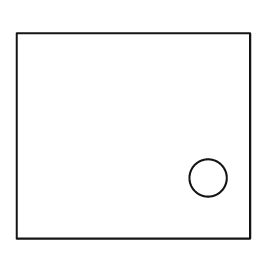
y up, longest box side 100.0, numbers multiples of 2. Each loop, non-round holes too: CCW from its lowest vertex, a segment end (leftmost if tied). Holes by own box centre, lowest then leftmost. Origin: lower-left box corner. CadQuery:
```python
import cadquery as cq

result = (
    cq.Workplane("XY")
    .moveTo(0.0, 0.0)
    .lineTo(100.0, 0.0)
    .lineTo(100.0, 88.0)
    .lineTo(0.0, 88.0)
    .close()
    .moveTo(82.0, 26.0)
    .circle(8.0)
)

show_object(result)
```